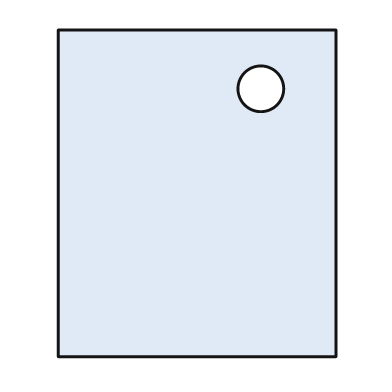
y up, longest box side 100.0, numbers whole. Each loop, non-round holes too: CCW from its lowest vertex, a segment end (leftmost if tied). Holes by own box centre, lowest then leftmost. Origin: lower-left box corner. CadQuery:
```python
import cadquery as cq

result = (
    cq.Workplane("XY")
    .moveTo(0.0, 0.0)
    .lineTo(85.0, 0.0)
    .lineTo(85.0, 100.0)
    .lineTo(0.0, 100.0)
    .close()
    .moveTo(62.0, 82.0)
    .circle(7.0)
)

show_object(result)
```